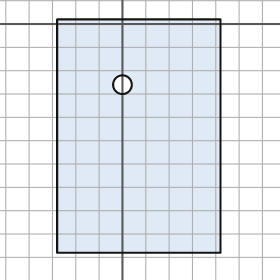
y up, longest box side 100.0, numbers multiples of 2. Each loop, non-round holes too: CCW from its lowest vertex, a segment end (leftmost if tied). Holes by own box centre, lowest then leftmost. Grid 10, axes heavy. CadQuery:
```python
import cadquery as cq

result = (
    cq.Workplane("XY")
    .moveTo(-28.0, -98.0)
    .lineTo(42.0, -98.0)
    .lineTo(42.0, 2.0)
    .lineTo(-28.0, 2.0)
    .close()
    .moveTo(0.0, -26.0)
    .circle(4.0)
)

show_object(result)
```